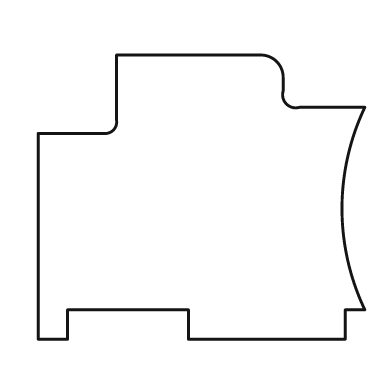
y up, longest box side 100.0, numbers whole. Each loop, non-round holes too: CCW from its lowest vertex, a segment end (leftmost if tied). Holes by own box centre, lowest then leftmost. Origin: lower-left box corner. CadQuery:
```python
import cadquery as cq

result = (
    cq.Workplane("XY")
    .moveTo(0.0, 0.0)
    .lineTo(9.0, 0.0)
    .lineTo(9.0, 9.0)
    .lineTo(46.0, 9.0)
    .lineTo(46.0, 0.0)
    .lineTo(94.0, 0.0)
    .lineTo(94.0, 9.0)
    .lineTo(100.0, 9.0)
    .threePointArc((93.0, 40.0), (100.0, 71.0))
    .lineTo(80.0, 71.0)
    .threePointArc((76.0, 72.0), (75.0, 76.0))
    .lineTo(75.0, 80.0)
    .threePointArc((73.0, 85.0), (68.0, 87.0))
    .lineTo(24.0, 87.0)
    .lineTo(24.0, 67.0)
    .threePointArc((23.0, 64.0), (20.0, 63.0))
    .lineTo(0.0, 63.0)
    .close()
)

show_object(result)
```